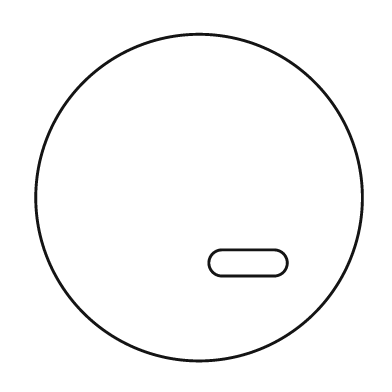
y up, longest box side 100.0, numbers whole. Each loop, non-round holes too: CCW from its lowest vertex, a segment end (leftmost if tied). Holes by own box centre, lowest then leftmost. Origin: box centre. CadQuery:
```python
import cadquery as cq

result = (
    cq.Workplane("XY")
    .moveTo(0.0, 0.0)
    .circle(50.0)
    .moveTo(7.0, -24.0)
    .lineTo(23.0, -24.0)
    .threePointArc((27.0, -20.0), (23.0, -16.0))
    .lineTo(7.0, -16.0)
    .threePointArc((3.0, -20.0), (7.0, -24.0))
    .close()
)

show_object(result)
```